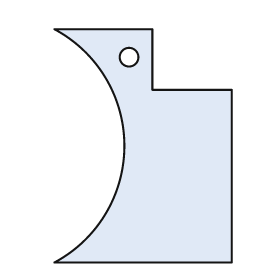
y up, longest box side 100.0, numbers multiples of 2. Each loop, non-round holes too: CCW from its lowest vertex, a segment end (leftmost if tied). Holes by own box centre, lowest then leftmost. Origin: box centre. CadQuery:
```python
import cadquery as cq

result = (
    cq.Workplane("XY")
    .moveTo(-38.0, -50.0)
    .lineTo(38.0, -50.0)
    .lineTo(38.0, 24.0)
    .lineTo(4.0, 24.0)
    .lineTo(4.0, 50.0)
    .lineTo(-38.0, 50.0)
    .threePointArc((-8.0, 0.0), (-38.0, -50.0))
    .close()
    .moveTo(-6.0, 38.0)
    .circle(4.0)
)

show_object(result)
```